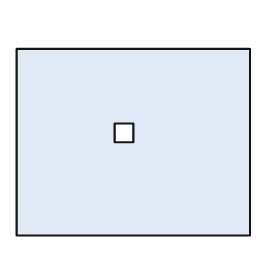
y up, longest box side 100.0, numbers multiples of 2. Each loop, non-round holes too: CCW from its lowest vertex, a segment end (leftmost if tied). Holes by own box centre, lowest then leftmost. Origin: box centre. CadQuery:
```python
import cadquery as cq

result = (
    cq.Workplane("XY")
    .moveTo(-50.0, -40.0)
    .lineTo(50.0, -40.0)
    .lineTo(50.0, 40.0)
    .lineTo(-50.0, 40.0)
    .close()
    .moveTo(-8.0, 0.0)
    .lineTo(0.0, 0.0)
    .lineTo(0.0, 8.0)
    .lineTo(-8.0, 8.0)
    .close()
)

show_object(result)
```